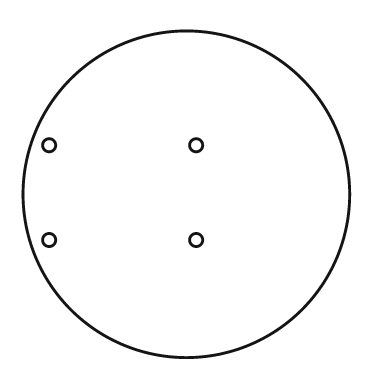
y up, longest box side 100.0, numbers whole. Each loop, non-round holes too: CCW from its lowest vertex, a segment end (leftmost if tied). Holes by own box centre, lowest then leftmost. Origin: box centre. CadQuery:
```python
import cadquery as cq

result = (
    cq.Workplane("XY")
    .moveTo(0.0, 0.0)
    .circle(50.0)
    .moveTo(-42.0, -14.0)
    .circle(2.0)
    .moveTo(3.0, -14.0)
    .circle(2.0)
    .moveTo(-42.0, 15.0)
    .circle(2.0)
    .moveTo(3.0, 15.0)
    .circle(2.0)
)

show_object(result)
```